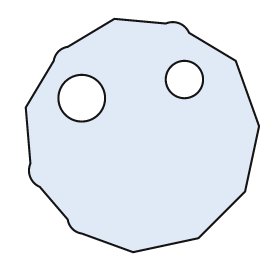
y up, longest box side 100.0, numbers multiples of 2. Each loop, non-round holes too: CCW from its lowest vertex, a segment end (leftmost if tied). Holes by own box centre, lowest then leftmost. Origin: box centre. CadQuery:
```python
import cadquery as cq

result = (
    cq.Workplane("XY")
    .moveTo(-4.0, -50.0)
    .lineTo(24.0, -44.0)
    .lineTo(44.0, -24.0)
    .lineTo(50.0, 4.0)
    .lineTo(40.0, 32.0)
    .lineTo(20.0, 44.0)
    .threePointArc((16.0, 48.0), (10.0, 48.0))
    .lineTo(-12.0, 50.0)
    .lineTo(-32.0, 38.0)
    .threePointArc((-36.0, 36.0), (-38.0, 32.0))
    .lineTo(-50.0, 12.0)
    .lineTo(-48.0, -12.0)
    .threePointArc((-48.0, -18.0), (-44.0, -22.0))
    .lineTo(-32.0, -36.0)
    .threePointArc((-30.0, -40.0), (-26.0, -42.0))
    .close()
    .moveTo(-26.0, 16.0)
    .circle(10.0)
    .moveTo(18.0, 24.0)
    .circle(8.0)
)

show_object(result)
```